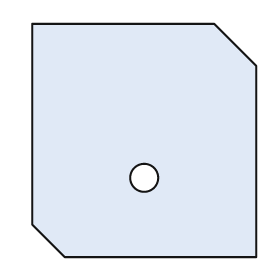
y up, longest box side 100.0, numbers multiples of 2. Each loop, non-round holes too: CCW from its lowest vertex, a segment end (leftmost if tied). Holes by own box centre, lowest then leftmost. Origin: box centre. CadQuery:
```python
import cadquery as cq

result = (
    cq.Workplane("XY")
    .moveTo(-34.0, -50.0)
    .lineTo(48.0, -50.0)
    .lineTo(48.0, 32.0)
    .lineTo(30.0, 50.0)
    .lineTo(-48.0, 50.0)
    .lineTo(-48.0, -36.0)
    .close()
    .moveTo(0.0, -16.0)
    .circle(6.0)
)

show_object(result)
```